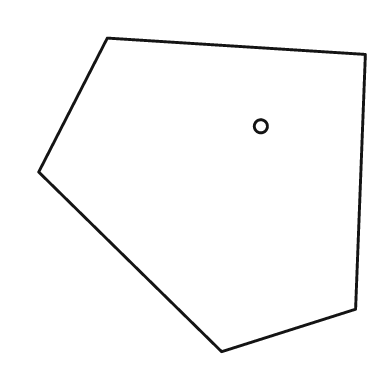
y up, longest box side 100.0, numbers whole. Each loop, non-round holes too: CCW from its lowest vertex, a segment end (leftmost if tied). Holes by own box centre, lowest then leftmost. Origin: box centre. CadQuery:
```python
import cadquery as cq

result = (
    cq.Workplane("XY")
    .moveTo(6.0, -48.0)
    .lineTo(47.0, -35.0)
    .lineTo(50.0, 43.0)
    .lineTo(-29.0, 48.0)
    .lineTo(-50.0, 7.0)
    .close()
    .moveTo(18.0, 21.0)
    .circle(2.0)
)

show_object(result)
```